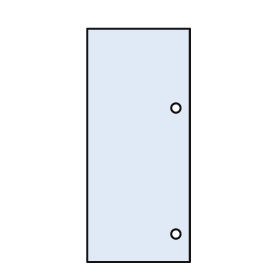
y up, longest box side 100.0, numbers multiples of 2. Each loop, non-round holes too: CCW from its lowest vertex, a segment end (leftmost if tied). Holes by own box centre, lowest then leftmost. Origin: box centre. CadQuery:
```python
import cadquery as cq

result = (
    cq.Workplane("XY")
    .moveTo(-22.0, -50.0)
    .lineTo(22.0, -50.0)
    .lineTo(22.0, 50.0)
    .lineTo(-22.0, 50.0)
    .close()
    .moveTo(16.0, -38.0)
    .circle(2.0)
    .moveTo(16.0, 16.0)
    .circle(2.0)
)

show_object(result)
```